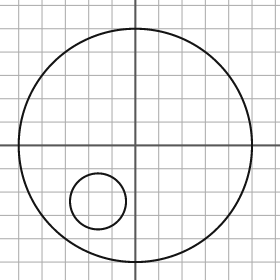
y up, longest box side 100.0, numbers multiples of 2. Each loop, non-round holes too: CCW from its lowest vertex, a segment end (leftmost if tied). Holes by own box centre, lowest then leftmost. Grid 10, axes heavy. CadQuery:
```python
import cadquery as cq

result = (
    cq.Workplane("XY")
    .moveTo(0.0, 0.0)
    .circle(50.0)
    .moveTo(-16.0, -24.0)
    .circle(12.0)
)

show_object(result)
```